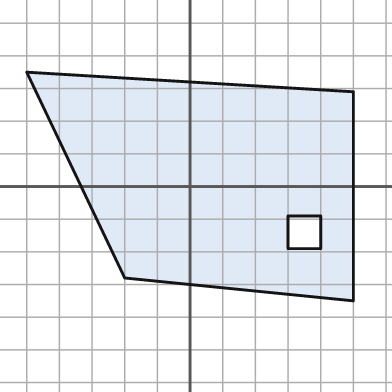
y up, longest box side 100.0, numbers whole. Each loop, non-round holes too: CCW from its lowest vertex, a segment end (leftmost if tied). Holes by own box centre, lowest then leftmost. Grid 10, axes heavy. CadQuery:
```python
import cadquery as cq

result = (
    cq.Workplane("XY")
    .moveTo(50.0, -35.0)
    .lineTo(50.0, 29.0)
    .lineTo(-50.0, 35.0)
    .lineTo(-20.0, -28.0)
    .close()
    .moveTo(30.0, -19.0)
    .lineTo(40.0, -19.0)
    .lineTo(40.0, -9.0)
    .lineTo(30.0, -9.0)
    .close()
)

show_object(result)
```